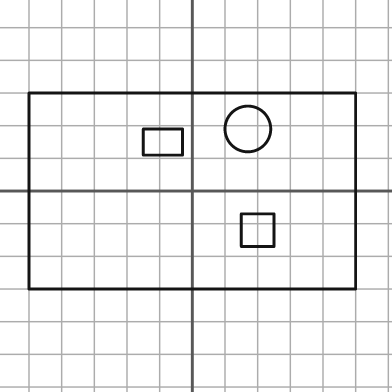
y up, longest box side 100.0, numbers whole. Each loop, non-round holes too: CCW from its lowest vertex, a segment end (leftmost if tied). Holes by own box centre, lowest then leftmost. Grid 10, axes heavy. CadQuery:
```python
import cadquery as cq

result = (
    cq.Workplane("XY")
    .moveTo(-50.0, -30.0)
    .lineTo(50.0, -30.0)
    .lineTo(50.0, 30.0)
    .lineTo(-50.0, 30.0)
    .close()
    .moveTo(15.0, -17.0)
    .lineTo(25.0, -17.0)
    .lineTo(25.0, -7.0)
    .lineTo(15.0, -7.0)
    .close()
    .moveTo(-15.0, 11.0)
    .lineTo(-3.0, 11.0)
    .lineTo(-3.0, 19.0)
    .lineTo(-15.0, 19.0)
    .close()
    .moveTo(17.0, 19.0)
    .circle(7.0)
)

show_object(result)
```